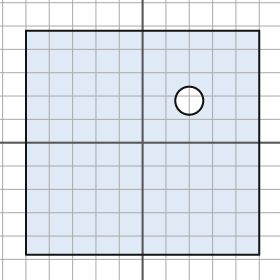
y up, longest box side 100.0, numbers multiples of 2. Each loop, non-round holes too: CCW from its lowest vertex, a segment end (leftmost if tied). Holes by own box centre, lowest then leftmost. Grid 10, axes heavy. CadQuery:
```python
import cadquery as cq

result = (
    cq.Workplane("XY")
    .moveTo(-50.0, -48.0)
    .lineTo(50.0, -48.0)
    .lineTo(50.0, 48.0)
    .lineTo(-50.0, 48.0)
    .close()
    .moveTo(20.0, 18.0)
    .circle(6.0)
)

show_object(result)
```